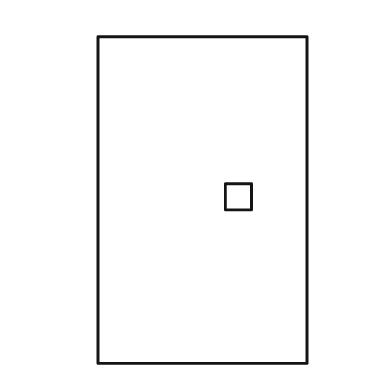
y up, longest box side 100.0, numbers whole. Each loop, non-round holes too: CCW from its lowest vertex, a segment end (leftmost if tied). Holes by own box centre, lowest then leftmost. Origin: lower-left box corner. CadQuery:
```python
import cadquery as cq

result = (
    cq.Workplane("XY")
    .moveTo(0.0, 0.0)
    .lineTo(64.0, 0.0)
    .lineTo(64.0, 100.0)
    .lineTo(0.0, 100.0)
    .close()
    .moveTo(39.0, 47.0)
    .lineTo(47.0, 47.0)
    .lineTo(47.0, 55.0)
    .lineTo(39.0, 55.0)
    .close()
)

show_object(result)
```